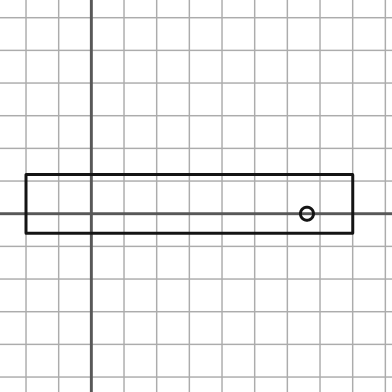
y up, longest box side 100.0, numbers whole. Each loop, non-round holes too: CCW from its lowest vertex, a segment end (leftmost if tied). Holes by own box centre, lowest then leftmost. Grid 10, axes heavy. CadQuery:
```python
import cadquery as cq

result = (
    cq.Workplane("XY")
    .moveTo(-20.0, -6.0)
    .lineTo(80.0, -6.0)
    .lineTo(80.0, 12.0)
    .lineTo(-20.0, 12.0)
    .close()
    .moveTo(66.0, 0.0)
    .circle(2.0)
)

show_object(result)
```